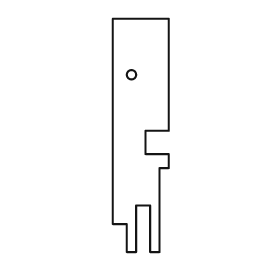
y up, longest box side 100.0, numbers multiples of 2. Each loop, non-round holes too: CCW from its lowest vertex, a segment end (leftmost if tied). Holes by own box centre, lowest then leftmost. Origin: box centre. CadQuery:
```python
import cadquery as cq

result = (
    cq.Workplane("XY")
    .moveTo(-6.0, -50.0)
    .lineTo(-2.0, -50.0)
    .lineTo(-2.0, -30.0)
    .lineTo(4.0, -30.0)
    .lineTo(4.0, -50.0)
    .lineTo(8.0, -50.0)
    .lineTo(8.0, -14.0)
    .lineTo(12.0, -14.0)
    .lineTo(12.0, -8.0)
    .lineTo(2.0, -8.0)
    .lineTo(2.0, 2.0)
    .lineTo(12.0, 2.0)
    .lineTo(12.0, 50.0)
    .lineTo(-12.0, 50.0)
    .lineTo(-12.0, -38.0)
    .lineTo(-6.0, -38.0)
    .close()
    .moveTo(-4.0, 26.0)
    .circle(2.0)
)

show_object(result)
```